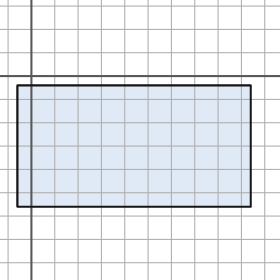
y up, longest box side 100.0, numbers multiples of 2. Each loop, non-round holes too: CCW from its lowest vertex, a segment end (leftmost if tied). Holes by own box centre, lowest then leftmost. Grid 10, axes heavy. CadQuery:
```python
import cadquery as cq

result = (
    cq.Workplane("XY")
    .moveTo(-6.0, -56.0)
    .lineTo(94.0, -56.0)
    .lineTo(94.0, -4.0)
    .lineTo(-6.0, -4.0)
    .close()
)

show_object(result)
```